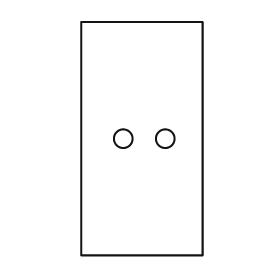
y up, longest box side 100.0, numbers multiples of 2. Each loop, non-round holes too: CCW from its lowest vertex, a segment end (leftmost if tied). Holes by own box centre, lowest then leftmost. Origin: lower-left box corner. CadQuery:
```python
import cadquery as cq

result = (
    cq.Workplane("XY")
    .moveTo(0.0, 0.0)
    .lineTo(52.0, 0.0)
    .lineTo(52.0, 100.0)
    .lineTo(0.0, 100.0)
    .close()
    .moveTo(18.0, 50.0)
    .circle(4.0)
    .moveTo(36.0, 50.0)
    .circle(4.0)
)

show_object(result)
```